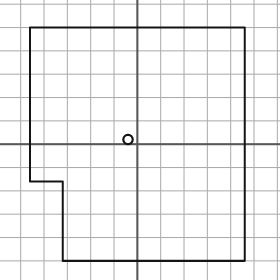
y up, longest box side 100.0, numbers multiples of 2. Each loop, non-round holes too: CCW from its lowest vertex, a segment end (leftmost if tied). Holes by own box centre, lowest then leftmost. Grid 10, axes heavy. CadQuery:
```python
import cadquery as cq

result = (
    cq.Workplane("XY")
    .moveTo(-32.0, -50.0)
    .lineTo(46.0, -50.0)
    .lineTo(46.0, 50.0)
    .lineTo(-46.0, 50.0)
    .lineTo(-46.0, -16.0)
    .lineTo(-32.0, -16.0)
    .close()
    .moveTo(-4.0, 2.0)
    .circle(2.0)
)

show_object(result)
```